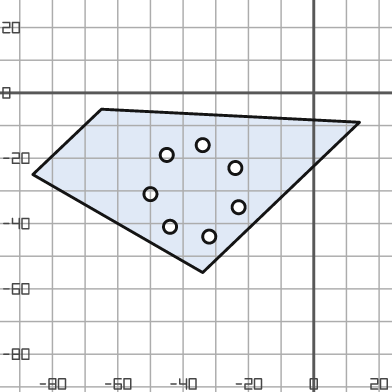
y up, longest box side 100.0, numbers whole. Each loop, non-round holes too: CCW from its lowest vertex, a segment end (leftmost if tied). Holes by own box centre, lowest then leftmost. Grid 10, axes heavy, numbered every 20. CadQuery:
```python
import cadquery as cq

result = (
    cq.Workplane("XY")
    .moveTo(-34.0, -55.0)
    .lineTo(14.0, -9.0)
    .lineTo(-65.0, -5.0)
    .lineTo(-86.0, -25.0)
    .close()
    .moveTo(-32.0, -44.0)
    .circle(2.0)
    .moveTo(-44.0, -41.0)
    .circle(2.0)
    .moveTo(-23.0, -35.0)
    .circle(2.0)
    .moveTo(-50.0, -31.0)
    .circle(2.0)
    .moveTo(-24.0, -23.0)
    .circle(2.0)
    .moveTo(-45.0, -19.0)
    .circle(2.0)
    .moveTo(-34.0, -16.0)
    .circle(2.0)
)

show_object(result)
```